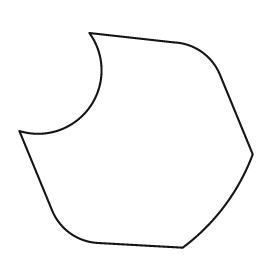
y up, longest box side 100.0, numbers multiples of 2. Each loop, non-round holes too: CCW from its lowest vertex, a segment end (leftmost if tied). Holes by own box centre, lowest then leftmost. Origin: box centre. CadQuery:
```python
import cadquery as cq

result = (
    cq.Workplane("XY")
    .moveTo(20.0, -46.0)
    .threePointArc((38.0, -28.0), (50.0, -6.0))
    .lineTo(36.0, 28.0)
    .threePointArc((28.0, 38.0), (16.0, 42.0))
    .lineTo(-20.0, 46.0)
    .threePointArc((-20.0, 14.0), (-50.0, 4.0))
    .lineTo(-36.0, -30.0)
    .threePointArc((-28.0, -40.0), (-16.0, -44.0))
    .close()
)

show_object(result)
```